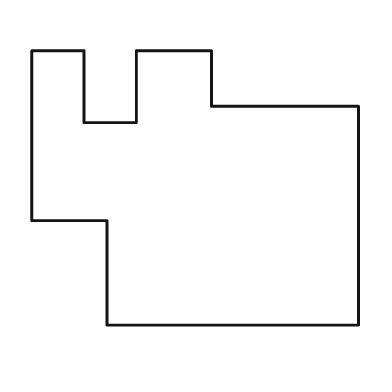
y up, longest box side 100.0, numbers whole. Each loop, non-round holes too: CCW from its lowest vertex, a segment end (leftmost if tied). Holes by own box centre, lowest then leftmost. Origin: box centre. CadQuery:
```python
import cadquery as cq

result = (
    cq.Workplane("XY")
    .moveTo(-27.0, -42.0)
    .lineTo(50.0, -42.0)
    .lineTo(50.0, 25.0)
    .lineTo(5.0, 25.0)
    .lineTo(5.0, 42.0)
    .lineTo(-18.0, 42.0)
    .lineTo(-18.0, 20.0)
    .lineTo(-34.0, 20.0)
    .lineTo(-34.0, 42.0)
    .lineTo(-50.0, 42.0)
    .lineTo(-50.0, -10.0)
    .lineTo(-27.0, -10.0)
    .close()
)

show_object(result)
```